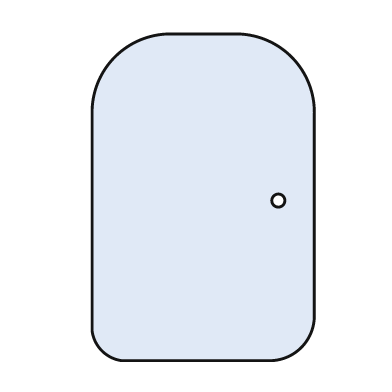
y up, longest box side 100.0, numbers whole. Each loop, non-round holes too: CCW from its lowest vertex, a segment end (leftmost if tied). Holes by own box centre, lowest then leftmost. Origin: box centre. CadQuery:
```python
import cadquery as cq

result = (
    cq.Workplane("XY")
    .moveTo(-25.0, -50.0)
    .lineTo(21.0, -50.0)
    .threePointArc((30.0, -46.0), (34.0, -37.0))
    .lineTo(34.0, 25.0)
    .threePointArc((27.0, 43.0), (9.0, 50.0))
    .lineTo(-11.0, 50.0)
    .threePointArc((-27.0, 43.0), (-34.0, 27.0))
    .lineTo(-34.0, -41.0)
    .threePointArc((-31.0, -47.0), (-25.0, -50.0))
    .close()
    .moveTo(23.0, -1.0)
    .circle(2.0)
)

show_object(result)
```